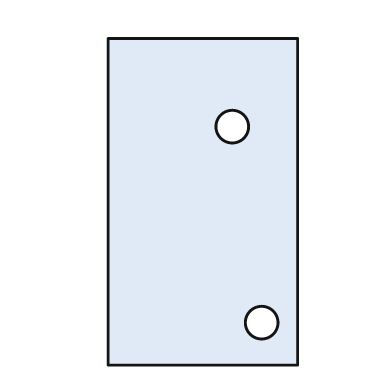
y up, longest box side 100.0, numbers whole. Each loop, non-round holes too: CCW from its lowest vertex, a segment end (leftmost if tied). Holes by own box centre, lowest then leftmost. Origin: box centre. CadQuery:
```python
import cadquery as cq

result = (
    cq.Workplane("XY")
    .moveTo(-29.0, -50.0)
    .lineTo(29.0, -50.0)
    .lineTo(29.0, 50.0)
    .lineTo(-29.0, 50.0)
    .close()
    .moveTo(18.0, -37.0)
    .circle(5.0)
    .moveTo(9.0, 23.0)
    .circle(5.0)
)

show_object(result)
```